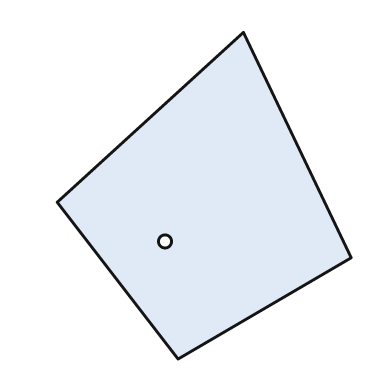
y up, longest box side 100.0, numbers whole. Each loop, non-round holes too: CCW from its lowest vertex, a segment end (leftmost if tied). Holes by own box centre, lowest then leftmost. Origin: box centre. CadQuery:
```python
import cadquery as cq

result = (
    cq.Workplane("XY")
    .moveTo(-8.0, -50.0)
    .lineTo(45.0, -19.0)
    .lineTo(12.0, 50.0)
    .lineTo(-45.0, -2.0)
    .close()
    .moveTo(-12.0, -14.0)
    .circle(2.0)
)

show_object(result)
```